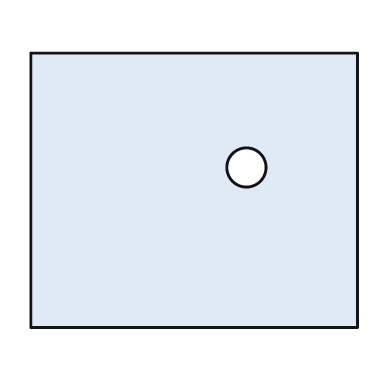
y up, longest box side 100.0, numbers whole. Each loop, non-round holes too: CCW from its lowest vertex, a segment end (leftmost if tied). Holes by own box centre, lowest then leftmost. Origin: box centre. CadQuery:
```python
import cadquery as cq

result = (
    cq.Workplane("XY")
    .moveTo(-50.0, -42.0)
    .lineTo(50.0, -42.0)
    .lineTo(50.0, 42.0)
    .lineTo(-50.0, 42.0)
    .close()
    .moveTo(16.0, 7.0)
    .circle(6.0)
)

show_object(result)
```